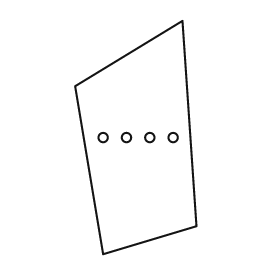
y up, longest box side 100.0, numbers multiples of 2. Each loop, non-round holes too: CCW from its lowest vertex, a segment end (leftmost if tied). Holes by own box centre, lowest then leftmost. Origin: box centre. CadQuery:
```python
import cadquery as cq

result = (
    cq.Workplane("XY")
    .moveTo(-14.0, -50.0)
    .lineTo(26.0, -38.0)
    .lineTo(20.0, 50.0)
    .lineTo(-26.0, 22.0)
    .close()
    .moveTo(-14.0, 0.0)
    .circle(2.0)
    .moveTo(-4.0, 0.0)
    .circle(2.0)
    .moveTo(6.0, 0.0)
    .circle(2.0)
    .moveTo(16.0, 0.0)
    .circle(2.0)
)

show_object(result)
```